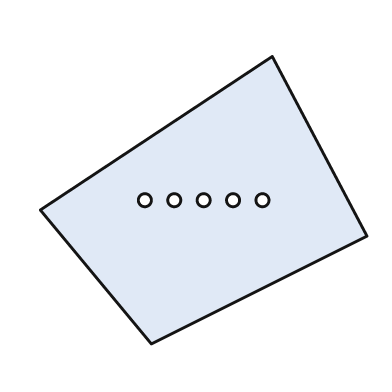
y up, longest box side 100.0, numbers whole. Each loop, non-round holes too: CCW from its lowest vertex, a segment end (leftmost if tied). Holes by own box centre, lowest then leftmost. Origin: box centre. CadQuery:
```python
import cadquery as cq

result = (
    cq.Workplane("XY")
    .moveTo(-16.0, -44.0)
    .lineTo(50.0, -11.0)
    .lineTo(21.0, 44.0)
    .lineTo(-50.0, -3.0)
    .close()
    .moveTo(-18.0, 0.0)
    .circle(2.0)
    .moveTo(-9.0, 0.0)
    .circle(2.0)
    .moveTo(0.0, 0.0)
    .circle(2.0)
    .moveTo(9.0, 0.0)
    .circle(2.0)
    .moveTo(18.0, 0.0)
    .circle(2.0)
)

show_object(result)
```